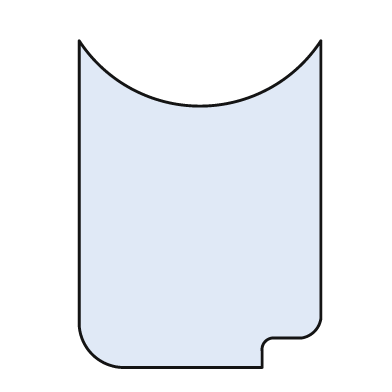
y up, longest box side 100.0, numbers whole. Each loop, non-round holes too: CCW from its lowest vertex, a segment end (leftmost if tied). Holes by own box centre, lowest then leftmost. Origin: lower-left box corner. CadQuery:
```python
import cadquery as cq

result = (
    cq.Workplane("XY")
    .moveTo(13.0, 0.0)
    .lineTo(56.0, 0.0)
    .lineTo(56.0, 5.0)
    .threePointArc((57.0, 8.0), (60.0, 9.0))
    .lineTo(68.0, 9.0)
    .threePointArc((72.0, 11.0), (74.0, 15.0))
    .lineTo(74.0, 100.0)
    .threePointArc((37.0, 80.0), (0.0, 100.0))
    .lineTo(0.0, 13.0)
    .threePointArc((4.0, 4.0), (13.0, 0.0))
    .close()
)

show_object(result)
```